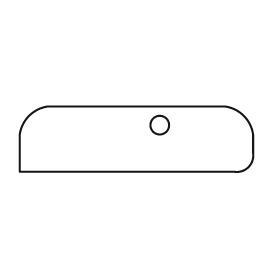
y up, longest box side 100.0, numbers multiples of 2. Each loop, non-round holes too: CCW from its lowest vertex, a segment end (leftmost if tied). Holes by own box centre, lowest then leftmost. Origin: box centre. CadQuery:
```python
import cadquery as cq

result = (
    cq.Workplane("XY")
    .moveTo(-50.0, -14.0)
    .lineTo(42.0, -14.0)
    .threePointArc((48.0, -12.0), (50.0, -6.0))
    .lineTo(50.0, 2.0)
    .threePointArc((46.0, 10.0), (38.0, 14.0))
    .lineTo(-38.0, 14.0)
    .threePointArc((-46.0, 10.0), (-50.0, 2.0))
    .close()
    .moveTo(10.0, 6.0)
    .circle(4.0)
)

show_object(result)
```